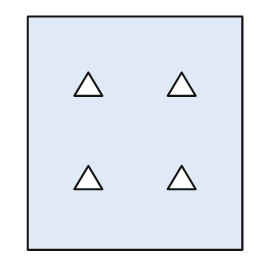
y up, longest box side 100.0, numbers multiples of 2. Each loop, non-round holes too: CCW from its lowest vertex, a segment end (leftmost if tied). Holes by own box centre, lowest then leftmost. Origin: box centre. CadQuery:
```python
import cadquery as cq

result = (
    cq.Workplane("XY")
    .moveTo(-46.0, -50.0)
    .lineTo(46.0, -50.0)
    .lineTo(46.0, 50.0)
    .lineTo(-46.0, 50.0)
    .close()
    .moveTo(-26.0, -24.0)
    .lineTo(-14.0, -24.0)
    .lineTo(-20.0, -14.0)
    .close()
    .moveTo(14.0, -24.0)
    .lineTo(26.0, -24.0)
    .lineTo(20.0, -14.0)
    .close()
    .moveTo(-26.0, 16.0)
    .lineTo(-14.0, 16.0)
    .lineTo(-20.0, 26.0)
    .close()
    .moveTo(14.0, 16.0)
    .lineTo(26.0, 16.0)
    .lineTo(20.0, 26.0)
    .close()
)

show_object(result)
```